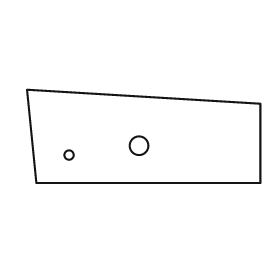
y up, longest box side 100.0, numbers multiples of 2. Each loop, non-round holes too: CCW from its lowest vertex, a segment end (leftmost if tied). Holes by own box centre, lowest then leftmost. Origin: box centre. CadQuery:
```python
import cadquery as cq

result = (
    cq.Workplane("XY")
    .moveTo(-46.0, -20.0)
    .lineTo(50.0, -20.0)
    .lineTo(50.0, 14.0)
    .lineTo(-50.0, 20.0)
    .close()
    .moveTo(-32.0, -8.0)
    .circle(2.0)
    .moveTo(-2.0, -4.0)
    .circle(4.0)
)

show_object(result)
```